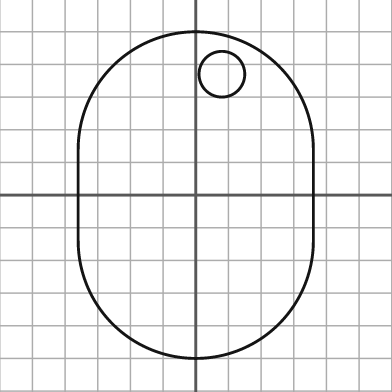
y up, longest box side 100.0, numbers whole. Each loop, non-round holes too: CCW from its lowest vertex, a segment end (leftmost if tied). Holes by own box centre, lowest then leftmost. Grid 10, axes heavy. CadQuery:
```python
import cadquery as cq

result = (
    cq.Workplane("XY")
    .moveTo(-36.0, -14.0)
    .threePointArc((0.0, -50.0), (36.0, -14.0))
    .lineTo(36.0, 14.0)
    .threePointArc((0.0, 50.0), (-36.0, 14.0))
    .close()
    .moveTo(8.0, 37.0)
    .circle(7.0)
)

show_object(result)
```